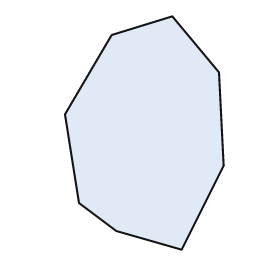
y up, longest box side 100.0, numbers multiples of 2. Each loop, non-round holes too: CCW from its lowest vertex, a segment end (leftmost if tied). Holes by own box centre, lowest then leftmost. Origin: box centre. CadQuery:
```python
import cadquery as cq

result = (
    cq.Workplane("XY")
    .moveTo(16.0, -50.0)
    .lineTo(34.0, -14.0)
    .lineTo(32.0, 26.0)
    .lineTo(12.0, 50.0)
    .lineTo(-14.0, 42.0)
    .lineTo(-34.0, 8.0)
    .lineTo(-28.0, -30.0)
    .lineTo(-12.0, -42.0)
    .close()
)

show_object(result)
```